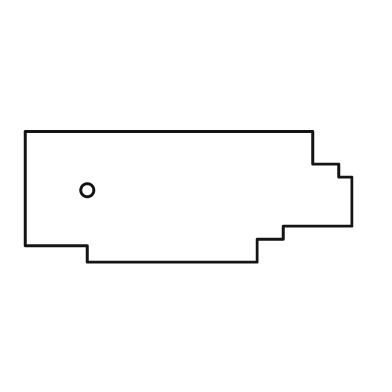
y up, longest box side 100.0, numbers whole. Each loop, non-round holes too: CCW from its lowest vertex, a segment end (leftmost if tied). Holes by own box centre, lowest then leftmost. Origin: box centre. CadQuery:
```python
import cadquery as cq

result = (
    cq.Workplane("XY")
    .moveTo(-31.0, -20.0)
    .lineTo(21.0, -20.0)
    .lineTo(21.0, -13.0)
    .lineTo(29.0, -13.0)
    .lineTo(29.0, -9.0)
    .lineTo(50.0, -9.0)
    .lineTo(50.0, 6.0)
    .lineTo(46.0, 6.0)
    .lineTo(46.0, 10.0)
    .lineTo(38.0, 10.0)
    .lineTo(38.0, 20.0)
    .lineTo(-50.0, 20.0)
    .lineTo(-50.0, -15.0)
    .lineTo(-31.0, -15.0)
    .close()
    .moveTo(-31.0, 2.0)
    .circle(2.0)
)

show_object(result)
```